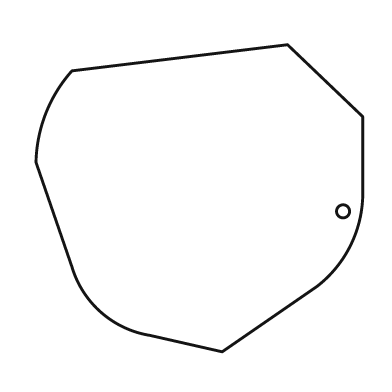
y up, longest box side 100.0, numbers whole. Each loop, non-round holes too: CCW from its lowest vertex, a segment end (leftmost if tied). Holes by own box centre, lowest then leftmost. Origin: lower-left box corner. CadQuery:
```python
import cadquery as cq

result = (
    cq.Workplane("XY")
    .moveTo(57.0, 0.0)
    .lineTo(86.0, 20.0)
    .threePointArc((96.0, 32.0), (100.0, 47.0))
    .lineTo(100.0, 72.0)
    .lineTo(77.0, 94.0)
    .lineTo(11.0, 86.0)
    .threePointArc((3.0, 73.0), (0.0, 58.0))
    .lineTo(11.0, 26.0)
    .threePointArc((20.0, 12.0), (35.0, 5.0))
    .close()
    .moveTo(94.0, 43.0)
    .circle(2.0)
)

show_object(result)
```